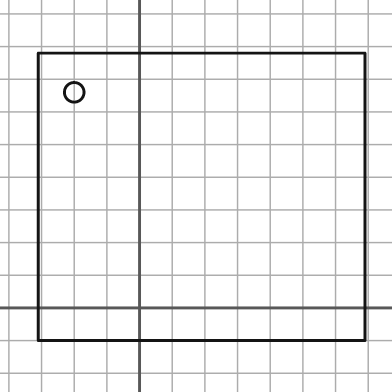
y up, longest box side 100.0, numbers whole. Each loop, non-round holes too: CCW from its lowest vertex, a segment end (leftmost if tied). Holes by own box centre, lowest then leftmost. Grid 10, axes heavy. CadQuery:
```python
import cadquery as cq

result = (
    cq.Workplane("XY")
    .moveTo(-31.0, -10.0)
    .lineTo(69.0, -10.0)
    .lineTo(69.0, 78.0)
    .lineTo(-31.0, 78.0)
    .close()
    .moveTo(-20.0, 66.0)
    .circle(3.0)
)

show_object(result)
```